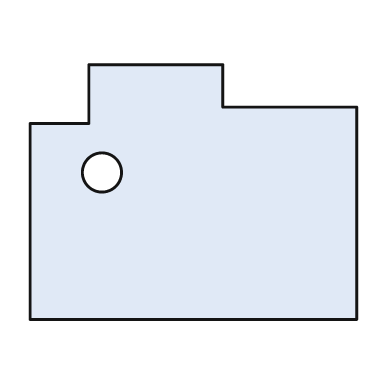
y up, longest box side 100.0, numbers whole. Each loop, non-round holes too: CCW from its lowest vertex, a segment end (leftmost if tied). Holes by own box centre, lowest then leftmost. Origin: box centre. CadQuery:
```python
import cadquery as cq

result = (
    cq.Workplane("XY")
    .moveTo(-50.0, -39.0)
    .lineTo(50.0, -39.0)
    .lineTo(50.0, 26.0)
    .lineTo(9.0, 26.0)
    .lineTo(9.0, 39.0)
    .lineTo(-32.0, 39.0)
    .lineTo(-32.0, 21.0)
    .lineTo(-50.0, 21.0)
    .close()
    .moveTo(-28.0, 6.0)
    .circle(6.0)
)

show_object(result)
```